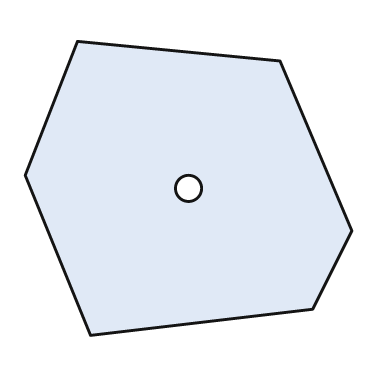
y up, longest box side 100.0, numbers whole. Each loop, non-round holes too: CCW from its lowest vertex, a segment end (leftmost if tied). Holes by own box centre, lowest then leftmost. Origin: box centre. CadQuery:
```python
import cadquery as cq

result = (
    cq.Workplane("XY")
    .moveTo(-30.0, -45.0)
    .lineTo(38.0, -37.0)
    .lineTo(50.0, -13.0)
    .lineTo(28.0, 39.0)
    .lineTo(-34.0, 45.0)
    .lineTo(-50.0, 4.0)
    .close()
    .moveTo(0.0, 0.0)
    .circle(4.0)
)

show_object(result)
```